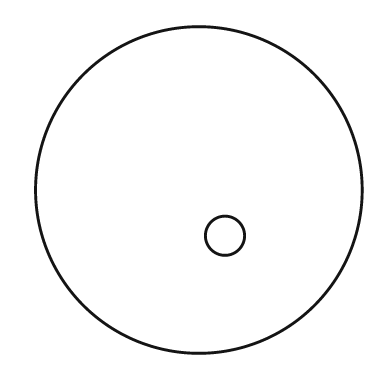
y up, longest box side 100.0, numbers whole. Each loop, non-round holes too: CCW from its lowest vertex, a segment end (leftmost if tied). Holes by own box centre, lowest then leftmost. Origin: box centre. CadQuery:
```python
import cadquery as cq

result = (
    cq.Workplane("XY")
    .moveTo(0.0, 0.0)
    .circle(50.0)
    .moveTo(8.0, -14.0)
    .circle(6.0)
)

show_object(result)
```